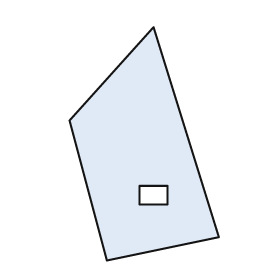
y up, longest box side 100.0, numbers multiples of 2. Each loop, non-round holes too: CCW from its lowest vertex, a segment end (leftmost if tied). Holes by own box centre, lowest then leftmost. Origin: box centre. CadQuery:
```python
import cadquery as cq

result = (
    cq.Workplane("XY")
    .moveTo(-16.0, -50.0)
    .lineTo(32.0, -40.0)
    .lineTo(4.0, 50.0)
    .lineTo(-32.0, 10.0)
    .close()
    .moveTo(-2.0, -26.0)
    .lineTo(10.0, -26.0)
    .lineTo(10.0, -18.0)
    .lineTo(-2.0, -18.0)
    .close()
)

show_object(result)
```